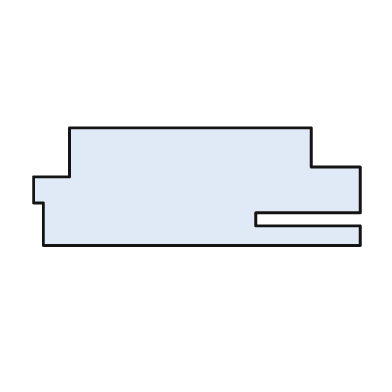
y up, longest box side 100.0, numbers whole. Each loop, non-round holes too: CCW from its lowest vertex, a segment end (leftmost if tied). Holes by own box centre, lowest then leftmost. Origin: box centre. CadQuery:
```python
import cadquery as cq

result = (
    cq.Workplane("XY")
    .moveTo(-47.0, -18.0)
    .lineTo(50.0, -18.0)
    .lineTo(50.0, -12.0)
    .lineTo(18.0, -12.0)
    .lineTo(18.0, -8.0)
    .lineTo(50.0, -8.0)
    .lineTo(50.0, 6.0)
    .lineTo(35.0, 6.0)
    .lineTo(35.0, 18.0)
    .lineTo(-39.0, 18.0)
    .lineTo(-39.0, 3.0)
    .lineTo(-50.0, 3.0)
    .lineTo(-50.0, -5.0)
    .lineTo(-47.0, -5.0)
    .close()
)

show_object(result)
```